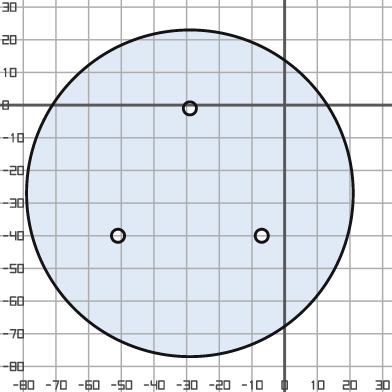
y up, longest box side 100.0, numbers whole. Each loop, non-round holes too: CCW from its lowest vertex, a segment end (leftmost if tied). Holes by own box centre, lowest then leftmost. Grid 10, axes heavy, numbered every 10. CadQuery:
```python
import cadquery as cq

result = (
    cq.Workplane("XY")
    .moveTo(-29.0, -27.0)
    .circle(50.0)
    .moveTo(-51.0, -40.0)
    .circle(2.0)
    .moveTo(-7.0, -40.0)
    .circle(2.0)
    .moveTo(-29.0, -1.0)
    .circle(2.0)
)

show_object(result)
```